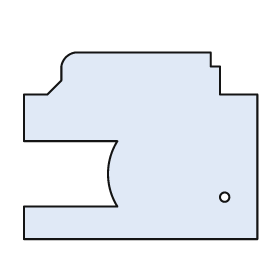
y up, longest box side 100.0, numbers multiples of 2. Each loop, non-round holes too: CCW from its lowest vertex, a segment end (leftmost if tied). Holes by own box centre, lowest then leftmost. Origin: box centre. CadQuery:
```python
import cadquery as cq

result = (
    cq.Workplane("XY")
    .moveTo(-50.0, -40.0)
    .lineTo(50.0, -40.0)
    .lineTo(50.0, 22.0)
    .lineTo(34.0, 22.0)
    .lineTo(34.0, 34.0)
    .lineTo(30.0, 34.0)
    .lineTo(30.0, 40.0)
    .lineTo(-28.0, 40.0)
    .threePointArc((-32.0, 38.0), (-34.0, 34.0))
    .lineTo(-34.0, 28.0)
    .lineTo(-40.0, 22.0)
    .lineTo(-50.0, 22.0)
    .lineTo(-50.0, 2.0)
    .lineTo(-10.0, 2.0)
    .threePointArc((-14.0, -12.0), (-10.0, -26.0))
    .lineTo(-50.0, -26.0)
    .close()
    .moveTo(36.0, -22.0)
    .circle(2.0)
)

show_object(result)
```